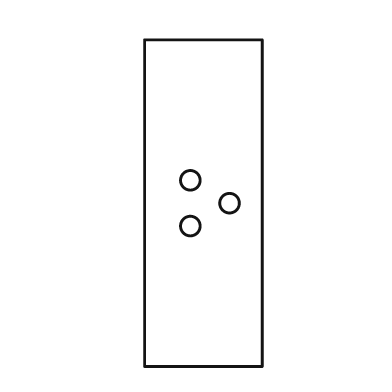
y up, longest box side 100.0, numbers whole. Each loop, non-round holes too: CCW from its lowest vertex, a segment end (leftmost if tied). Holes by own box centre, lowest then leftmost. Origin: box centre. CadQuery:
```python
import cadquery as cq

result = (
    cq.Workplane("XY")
    .moveTo(-18.0, -50.0)
    .lineTo(18.0, -50.0)
    .lineTo(18.0, 50.0)
    .lineTo(-18.0, 50.0)
    .close()
    .moveTo(-4.0, -7.0)
    .circle(3.0)
    .moveTo(8.0, 0.0)
    .circle(3.0)
    .moveTo(-4.0, 7.0)
    .circle(3.0)
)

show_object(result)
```